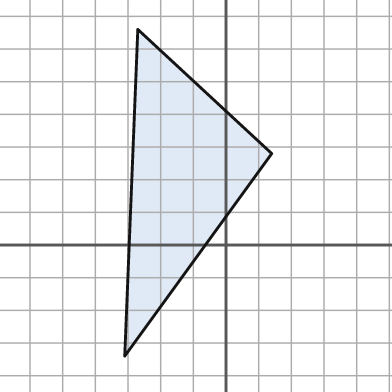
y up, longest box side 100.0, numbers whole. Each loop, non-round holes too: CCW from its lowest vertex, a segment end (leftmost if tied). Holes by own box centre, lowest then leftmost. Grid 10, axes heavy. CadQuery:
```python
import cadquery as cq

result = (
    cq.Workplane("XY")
    .moveTo(-31.0, -34.0)
    .lineTo(14.0, 28.0)
    .lineTo(-27.0, 66.0)
    .close()
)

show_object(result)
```